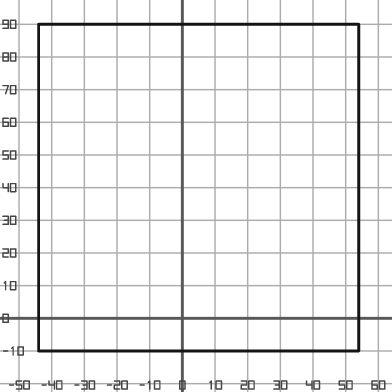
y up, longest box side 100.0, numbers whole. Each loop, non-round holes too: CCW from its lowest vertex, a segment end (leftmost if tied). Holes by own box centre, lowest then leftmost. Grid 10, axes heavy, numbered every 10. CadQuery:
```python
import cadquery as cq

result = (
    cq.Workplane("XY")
    .moveTo(-44.0, -10.0)
    .lineTo(54.0, -10.0)
    .lineTo(54.0, 90.0)
    .lineTo(-44.0, 90.0)
    .close()
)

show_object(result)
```